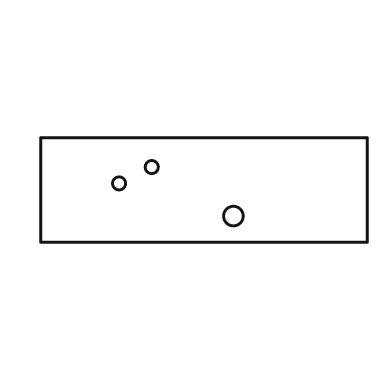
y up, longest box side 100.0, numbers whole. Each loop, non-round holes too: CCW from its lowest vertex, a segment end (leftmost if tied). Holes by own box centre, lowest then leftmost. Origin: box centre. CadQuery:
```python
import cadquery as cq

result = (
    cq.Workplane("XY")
    .moveTo(-50.0, -16.0)
    .lineTo(50.0, -16.0)
    .lineTo(50.0, 16.0)
    .lineTo(-50.0, 16.0)
    .close()
    .moveTo(9.0, -8.0)
    .circle(3.0)
    .moveTo(-26.0, 2.0)
    .circle(2.0)
    .moveTo(-16.0, 7.0)
    .circle(2.0)
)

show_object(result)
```